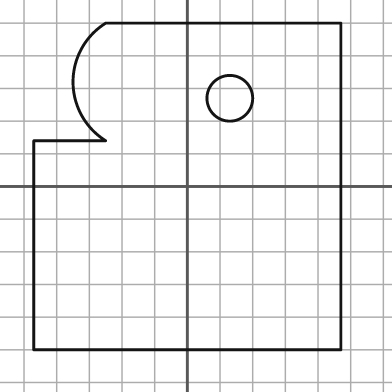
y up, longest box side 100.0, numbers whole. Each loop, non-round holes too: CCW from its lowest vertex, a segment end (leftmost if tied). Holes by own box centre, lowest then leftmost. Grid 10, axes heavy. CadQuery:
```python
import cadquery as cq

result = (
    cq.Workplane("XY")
    .moveTo(-47.0, -50.0)
    .lineTo(47.0, -50.0)
    .lineTo(47.0, 50.0)
    .lineTo(-25.0, 50.0)
    .threePointArc((-35.0, 32.0), (-25.0, 14.0))
    .lineTo(-47.0, 14.0)
    .close()
    .moveTo(13.0, 27.0)
    .circle(7.0)
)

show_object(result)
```